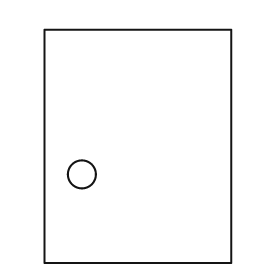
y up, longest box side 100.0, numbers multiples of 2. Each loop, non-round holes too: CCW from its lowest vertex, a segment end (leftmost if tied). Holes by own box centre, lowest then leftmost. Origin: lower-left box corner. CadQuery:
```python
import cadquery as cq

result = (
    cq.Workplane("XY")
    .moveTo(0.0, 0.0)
    .lineTo(80.0, 0.0)
    .lineTo(80.0, 100.0)
    .lineTo(0.0, 100.0)
    .close()
    .moveTo(16.0, 38.0)
    .circle(6.0)
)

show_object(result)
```